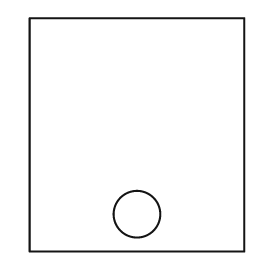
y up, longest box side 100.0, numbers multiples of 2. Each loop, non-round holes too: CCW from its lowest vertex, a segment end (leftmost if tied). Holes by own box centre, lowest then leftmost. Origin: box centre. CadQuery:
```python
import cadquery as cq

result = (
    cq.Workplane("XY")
    .moveTo(-46.0, -50.0)
    .lineTo(46.0, -50.0)
    .lineTo(46.0, 50.0)
    .lineTo(-46.0, 50.0)
    .close()
    .moveTo(0.0, -34.0)
    .circle(10.0)
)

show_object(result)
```